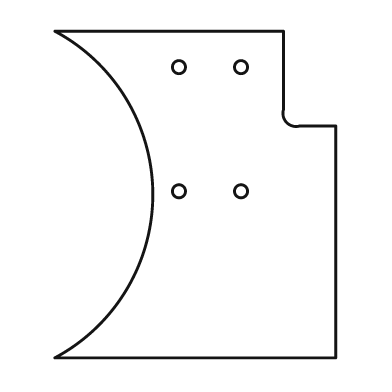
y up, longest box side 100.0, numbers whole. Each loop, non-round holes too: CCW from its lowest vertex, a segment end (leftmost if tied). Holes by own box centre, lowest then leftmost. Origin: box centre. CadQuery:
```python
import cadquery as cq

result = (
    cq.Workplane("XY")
    .moveTo(-43.0, -50.0)
    .lineTo(43.0, -50.0)
    .lineTo(43.0, 21.0)
    .lineTo(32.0, 21.0)
    .threePointArc((28.0, 22.0), (27.0, 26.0))
    .lineTo(27.0, 50.0)
    .lineTo(-43.0, 50.0)
    .threePointArc((-13.0, 0.0), (-43.0, -50.0))
    .close()
    .moveTo(-5.0, 1.0)
    .circle(2.0)
    .moveTo(14.0, 1.0)
    .circle(2.0)
    .moveTo(-5.0, 39.0)
    .circle(2.0)
    .moveTo(14.0, 39.0)
    .circle(2.0)
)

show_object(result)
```